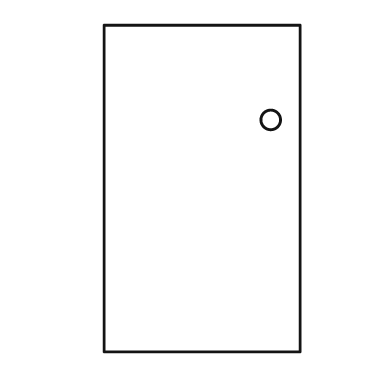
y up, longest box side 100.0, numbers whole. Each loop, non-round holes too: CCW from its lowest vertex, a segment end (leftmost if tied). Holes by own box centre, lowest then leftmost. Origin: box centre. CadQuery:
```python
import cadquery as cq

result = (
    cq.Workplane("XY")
    .moveTo(-30.0, -50.0)
    .lineTo(30.0, -50.0)
    .lineTo(30.0, 50.0)
    .lineTo(-30.0, 50.0)
    .close()
    .moveTo(21.0, 21.0)
    .circle(3.0)
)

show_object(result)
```